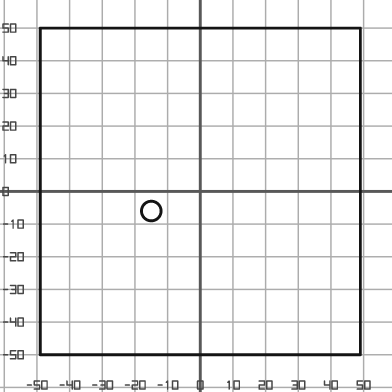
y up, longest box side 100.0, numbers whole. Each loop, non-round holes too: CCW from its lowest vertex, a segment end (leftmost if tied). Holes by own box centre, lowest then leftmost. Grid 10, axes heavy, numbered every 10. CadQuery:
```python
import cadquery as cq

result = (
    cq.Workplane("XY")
    .moveTo(-49.0, -50.0)
    .lineTo(49.0, -50.0)
    .lineTo(49.0, 50.0)
    .lineTo(-49.0, 50.0)
    .close()
    .moveTo(-15.0, -6.0)
    .circle(3.0)
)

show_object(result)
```